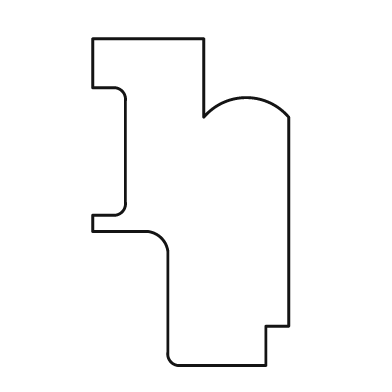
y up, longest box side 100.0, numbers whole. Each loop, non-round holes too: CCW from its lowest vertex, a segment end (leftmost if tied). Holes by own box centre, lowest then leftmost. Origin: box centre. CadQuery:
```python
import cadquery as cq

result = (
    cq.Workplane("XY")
    .moveTo(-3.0, -50.0)
    .lineTo(23.0, -50.0)
    .lineTo(23.0, -38.0)
    .lineTo(30.0, -38.0)
    .lineTo(30.0, 26.0)
    .threePointArc((17.0, 32.0), (4.0, 26.0))
    .lineTo(4.0, 50.0)
    .lineTo(-30.0, 50.0)
    .lineTo(-30.0, 35.0)
    .lineTo(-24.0, 35.0)
    .threePointArc((-21.0, 34.0), (-20.0, 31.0))
    .lineTo(-20.0, 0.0)
    .threePointArc((-21.0, -3.0), (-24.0, -4.0))
    .lineTo(-30.0, -4.0)
    .lineTo(-30.0, -9.0)
    .lineTo(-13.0, -9.0)
    .threePointArc((-9.0, -11.0), (-7.0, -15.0))
    .lineTo(-7.0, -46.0)
    .threePointArc((-6.0, -49.0), (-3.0, -50.0))
    .close()
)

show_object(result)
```